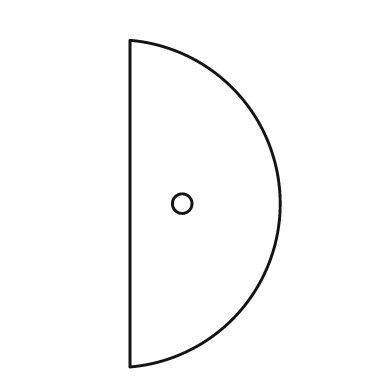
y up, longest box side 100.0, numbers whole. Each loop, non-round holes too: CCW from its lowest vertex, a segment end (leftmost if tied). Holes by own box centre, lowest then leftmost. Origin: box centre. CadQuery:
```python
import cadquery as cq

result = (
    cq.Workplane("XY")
    .moveTo(-23.0, -50.0)
    .threePointArc((23.0, 0.0), (-23.0, 50.0))
    .close()
    .moveTo(-7.0, 0.0)
    .circle(3.0)
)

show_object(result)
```